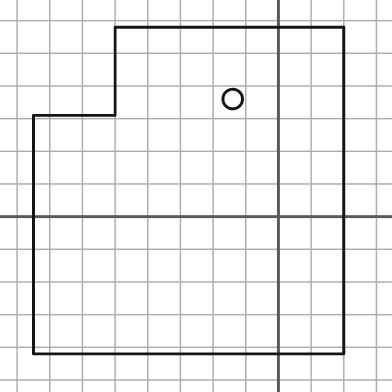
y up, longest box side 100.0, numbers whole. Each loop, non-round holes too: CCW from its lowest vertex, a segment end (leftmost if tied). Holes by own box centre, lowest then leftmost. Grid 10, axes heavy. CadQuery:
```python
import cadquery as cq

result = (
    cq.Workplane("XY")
    .moveTo(-75.0, -42.0)
    .lineTo(20.0, -42.0)
    .lineTo(20.0, 58.0)
    .lineTo(-50.0, 58.0)
    .lineTo(-50.0, 31.0)
    .lineTo(-75.0, 31.0)
    .close()
    .moveTo(-14.0, 36.0)
    .circle(3.0)
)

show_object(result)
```